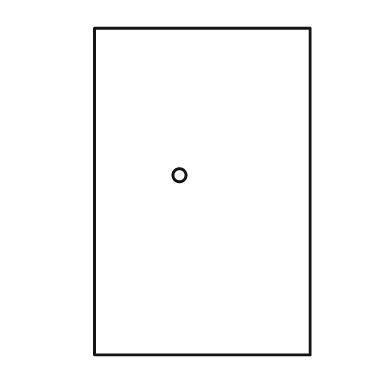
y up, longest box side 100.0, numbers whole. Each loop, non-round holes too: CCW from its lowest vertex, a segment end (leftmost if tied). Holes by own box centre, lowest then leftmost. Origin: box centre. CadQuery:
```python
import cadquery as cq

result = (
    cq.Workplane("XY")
    .moveTo(-33.0, -50.0)
    .lineTo(33.0, -50.0)
    .lineTo(33.0, 50.0)
    .lineTo(-33.0, 50.0)
    .close()
    .moveTo(-7.0, 5.0)
    .circle(2.0)
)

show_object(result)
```